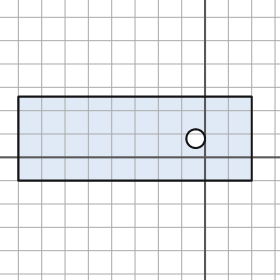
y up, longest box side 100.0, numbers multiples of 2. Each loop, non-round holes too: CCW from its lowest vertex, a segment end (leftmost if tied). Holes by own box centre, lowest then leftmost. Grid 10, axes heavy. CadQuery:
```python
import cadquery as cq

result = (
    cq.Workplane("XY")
    .moveTo(-80.0, -10.0)
    .lineTo(20.0, -10.0)
    .lineTo(20.0, 26.0)
    .lineTo(-80.0, 26.0)
    .close()
    .moveTo(-4.0, 8.0)
    .circle(4.0)
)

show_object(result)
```